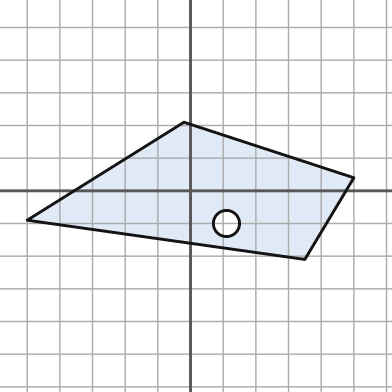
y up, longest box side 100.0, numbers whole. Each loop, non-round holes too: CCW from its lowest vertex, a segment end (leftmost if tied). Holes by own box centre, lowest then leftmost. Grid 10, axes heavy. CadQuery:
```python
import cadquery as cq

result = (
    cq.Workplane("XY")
    .moveTo(35.0, -21.0)
    .lineTo(50.0, 4.0)
    .lineTo(-2.0, 21.0)
    .lineTo(-50.0, -9.0)
    .close()
    .moveTo(11.0, -10.0)
    .circle(4.0)
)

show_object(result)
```